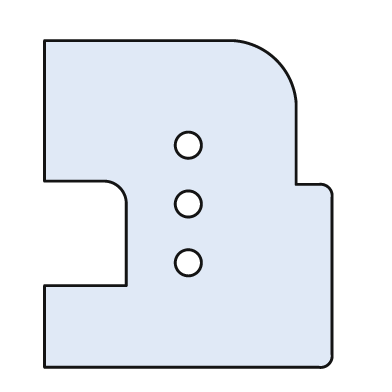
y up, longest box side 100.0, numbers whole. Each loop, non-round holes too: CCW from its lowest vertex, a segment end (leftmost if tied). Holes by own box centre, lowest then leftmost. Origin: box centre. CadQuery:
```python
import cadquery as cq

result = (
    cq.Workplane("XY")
    .moveTo(-44.0, -50.0)
    .lineTo(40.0, -50.0)
    .threePointArc((43.0, -49.0), (44.0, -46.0))
    .lineTo(44.0, 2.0)
    .threePointArc((43.0, 5.0), (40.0, 6.0))
    .lineTo(33.0, 6.0)
    .lineTo(33.0, 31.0)
    .threePointArc((27.0, 44.0), (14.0, 50.0))
    .lineTo(-44.0, 50.0)
    .lineTo(-44.0, 7.0)
    .lineTo(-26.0, 7.0)
    .threePointArc((-21.0, 5.0), (-19.0, 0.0))
    .lineTo(-19.0, -25.0)
    .lineTo(-44.0, -25.0)
    .close()
    .moveTo(0.0, -18.0)
    .circle(4.0)
    .moveTo(0.0, 0.0)
    .circle(4.0)
    .moveTo(0.0, 18.0)
    .circle(4.0)
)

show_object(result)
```